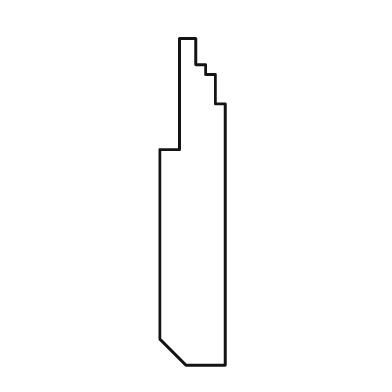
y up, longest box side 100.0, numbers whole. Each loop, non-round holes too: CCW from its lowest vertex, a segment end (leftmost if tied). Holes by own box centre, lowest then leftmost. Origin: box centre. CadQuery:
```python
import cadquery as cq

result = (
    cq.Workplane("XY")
    .moveTo(-2.0, -50.0)
    .lineTo(10.0, -50.0)
    .lineTo(10.0, 30.0)
    .lineTo(7.0, 30.0)
    .lineTo(7.0, 39.0)
    .lineTo(4.0, 39.0)
    .lineTo(4.0, 42.0)
    .lineTo(1.0, 42.0)
    .lineTo(1.0, 50.0)
    .lineTo(-4.0, 50.0)
    .lineTo(-4.0, 16.0)
    .lineTo(-10.0, 16.0)
    .lineTo(-10.0, -42.0)
    .close()
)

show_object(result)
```